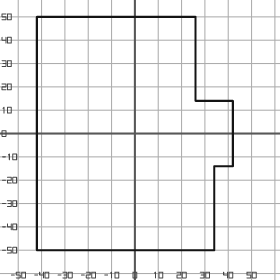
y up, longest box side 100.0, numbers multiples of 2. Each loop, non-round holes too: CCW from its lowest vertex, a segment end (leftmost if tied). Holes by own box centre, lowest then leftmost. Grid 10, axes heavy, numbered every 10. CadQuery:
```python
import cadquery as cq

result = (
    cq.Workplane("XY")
    .moveTo(-42.0, -50.0)
    .lineTo(34.0, -50.0)
    .lineTo(34.0, -14.0)
    .lineTo(42.0, -14.0)
    .lineTo(42.0, 14.0)
    .lineTo(26.0, 14.0)
    .lineTo(26.0, 50.0)
    .lineTo(-42.0, 50.0)
    .close()
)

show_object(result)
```